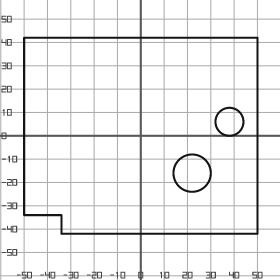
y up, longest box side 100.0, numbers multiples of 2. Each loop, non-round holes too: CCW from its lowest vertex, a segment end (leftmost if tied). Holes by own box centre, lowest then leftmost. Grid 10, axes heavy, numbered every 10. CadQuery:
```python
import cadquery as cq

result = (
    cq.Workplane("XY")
    .moveTo(-34.0, -42.0)
    .lineTo(50.0, -42.0)
    .lineTo(50.0, 42.0)
    .lineTo(-50.0, 42.0)
    .lineTo(-50.0, -34.0)
    .lineTo(-34.0, -34.0)
    .close()
    .moveTo(22.0, -16.0)
    .circle(8.0)
    .moveTo(38.0, 6.0)
    .circle(6.0)
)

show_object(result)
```